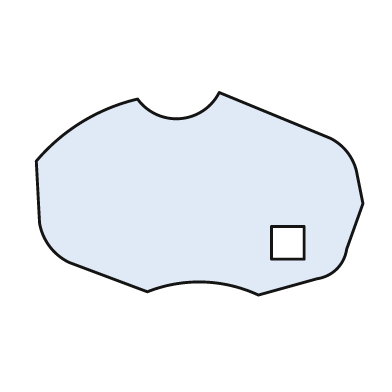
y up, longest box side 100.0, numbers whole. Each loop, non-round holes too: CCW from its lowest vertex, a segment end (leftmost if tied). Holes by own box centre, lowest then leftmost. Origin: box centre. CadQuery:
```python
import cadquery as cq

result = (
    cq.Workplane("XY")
    .moveTo(18.0, -31.0)
    .lineTo(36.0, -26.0)
    .threePointArc((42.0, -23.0), (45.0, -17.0))
    .lineTo(50.0, -3.0)
    .lineTo(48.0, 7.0)
    .threePointArc((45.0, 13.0), (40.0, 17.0))
    .lineTo(6.0, 31.0)
    .threePointArc((-6.0, 23.0), (-19.0, 29.0))
    .threePointArc((-36.0, 22.0), (-50.0, 10.0))
    .lineTo(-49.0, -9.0)
    .threePointArc((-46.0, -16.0), (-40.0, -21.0))
    .lineTo(-16.0, -30.0)
    .threePointArc((1.0, -27.0), (18.0, -31.0))
    .close()
    .moveTo(22.0, -20.0)
    .lineTo(32.0, -20.0)
    .lineTo(32.0, -10.0)
    .lineTo(22.0, -10.0)
    .close()
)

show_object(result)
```